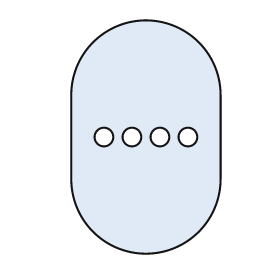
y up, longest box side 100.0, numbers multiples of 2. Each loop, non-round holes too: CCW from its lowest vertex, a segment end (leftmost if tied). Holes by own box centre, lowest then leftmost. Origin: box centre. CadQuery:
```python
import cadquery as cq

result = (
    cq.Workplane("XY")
    .moveTo(-32.0, -18.0)
    .threePointArc((0.0, -50.0), (32.0, -18.0))
    .lineTo(32.0, 18.0)
    .threePointArc((0.0, 50.0), (-32.0, 18.0))
    .close()
    .moveTo(-18.0, 0.0)
    .circle(4.0)
    .moveTo(-6.0, 0.0)
    .circle(4.0)
    .moveTo(6.0, 0.0)
    .circle(4.0)
    .moveTo(18.0, 0.0)
    .circle(4.0)
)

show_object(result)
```